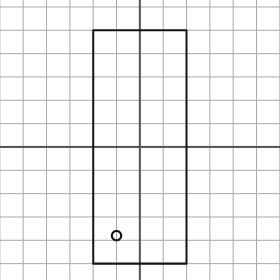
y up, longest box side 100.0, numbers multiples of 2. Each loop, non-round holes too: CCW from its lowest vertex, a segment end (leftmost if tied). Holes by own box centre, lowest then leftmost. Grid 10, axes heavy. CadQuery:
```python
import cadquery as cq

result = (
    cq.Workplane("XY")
    .moveTo(-20.0, -50.0)
    .lineTo(20.0, -50.0)
    .lineTo(20.0, 50.0)
    .lineTo(-20.0, 50.0)
    .close()
    .moveTo(-10.0, -38.0)
    .circle(2.0)
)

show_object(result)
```